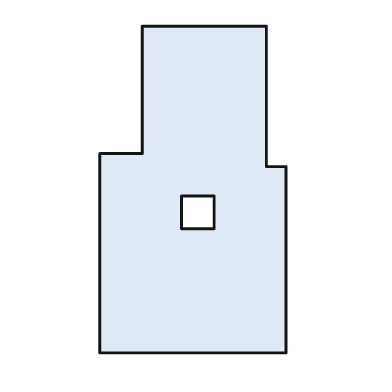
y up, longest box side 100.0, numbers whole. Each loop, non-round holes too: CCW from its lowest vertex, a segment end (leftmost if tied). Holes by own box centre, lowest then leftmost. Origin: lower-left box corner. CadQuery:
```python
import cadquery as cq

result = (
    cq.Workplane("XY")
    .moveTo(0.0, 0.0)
    .lineTo(57.0, 0.0)
    .lineTo(57.0, 57.0)
    .lineTo(51.0, 57.0)
    .lineTo(51.0, 100.0)
    .lineTo(13.0, 100.0)
    .lineTo(13.0, 61.0)
    .lineTo(0.0, 61.0)
    .close()
    .moveTo(25.0, 38.0)
    .lineTo(35.0, 38.0)
    .lineTo(35.0, 48.0)
    .lineTo(25.0, 48.0)
    .close()
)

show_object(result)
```